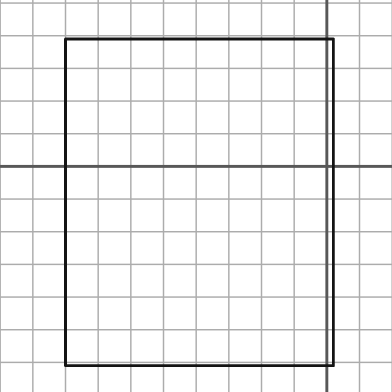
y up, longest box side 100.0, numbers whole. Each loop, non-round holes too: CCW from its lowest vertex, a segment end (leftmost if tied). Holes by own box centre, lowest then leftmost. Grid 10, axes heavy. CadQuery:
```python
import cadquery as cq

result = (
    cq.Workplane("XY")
    .moveTo(-80.0, -61.0)
    .lineTo(2.0, -61.0)
    .lineTo(2.0, 39.0)
    .lineTo(-80.0, 39.0)
    .close()
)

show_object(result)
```